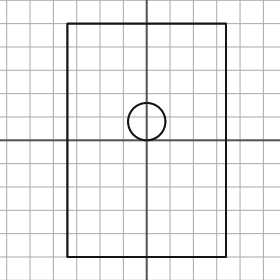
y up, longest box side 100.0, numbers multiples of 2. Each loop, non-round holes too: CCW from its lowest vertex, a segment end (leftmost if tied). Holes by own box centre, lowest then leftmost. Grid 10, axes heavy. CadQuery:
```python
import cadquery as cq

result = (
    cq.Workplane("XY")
    .moveTo(-34.0, -50.0)
    .lineTo(34.0, -50.0)
    .lineTo(34.0, 50.0)
    .lineTo(-34.0, 50.0)
    .close()
    .moveTo(0.0, 8.0)
    .circle(8.0)
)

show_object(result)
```